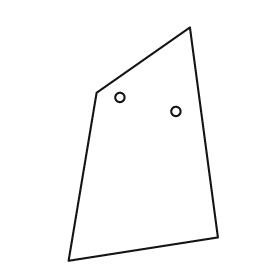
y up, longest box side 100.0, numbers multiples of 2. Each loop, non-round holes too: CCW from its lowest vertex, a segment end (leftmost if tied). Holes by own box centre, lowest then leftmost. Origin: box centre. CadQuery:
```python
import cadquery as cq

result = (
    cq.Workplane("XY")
    .moveTo(-32.0, -50.0)
    .lineTo(32.0, -40.0)
    .lineTo(20.0, 50.0)
    .lineTo(-20.0, 22.0)
    .close()
    .moveTo(14.0, 14.0)
    .circle(2.0)
    .moveTo(-10.0, 20.0)
    .circle(2.0)
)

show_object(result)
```